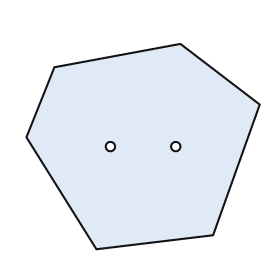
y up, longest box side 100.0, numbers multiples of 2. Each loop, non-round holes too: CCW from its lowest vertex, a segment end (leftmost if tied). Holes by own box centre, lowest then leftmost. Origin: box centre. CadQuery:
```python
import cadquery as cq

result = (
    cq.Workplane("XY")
    .moveTo(-20.0, -44.0)
    .lineTo(30.0, -38.0)
    .lineTo(50.0, 18.0)
    .lineTo(16.0, 44.0)
    .lineTo(-38.0, 34.0)
    .lineTo(-50.0, 4.0)
    .close()
    .moveTo(-14.0, 0.0)
    .circle(2.0)
    .moveTo(14.0, 0.0)
    .circle(2.0)
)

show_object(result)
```